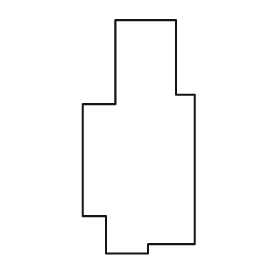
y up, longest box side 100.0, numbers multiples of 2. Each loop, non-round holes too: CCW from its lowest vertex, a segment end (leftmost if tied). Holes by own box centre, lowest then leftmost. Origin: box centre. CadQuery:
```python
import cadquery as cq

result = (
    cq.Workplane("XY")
    .moveTo(-14.0, -50.0)
    .lineTo(4.0, -50.0)
    .lineTo(4.0, -46.0)
    .lineTo(24.0, -46.0)
    .lineTo(24.0, 18.0)
    .lineTo(16.0, 18.0)
    .lineTo(16.0, 50.0)
    .lineTo(-10.0, 50.0)
    .lineTo(-10.0, 14.0)
    .lineTo(-24.0, 14.0)
    .lineTo(-24.0, -34.0)
    .lineTo(-14.0, -34.0)
    .close()
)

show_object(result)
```